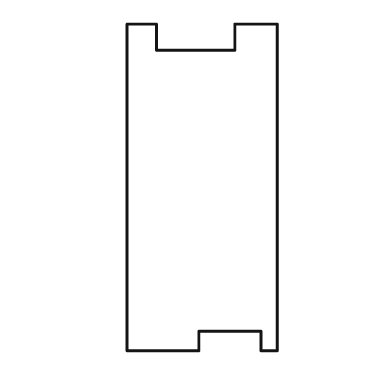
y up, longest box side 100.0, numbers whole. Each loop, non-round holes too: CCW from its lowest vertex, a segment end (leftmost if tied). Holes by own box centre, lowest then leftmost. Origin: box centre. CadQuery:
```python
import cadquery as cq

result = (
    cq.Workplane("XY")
    .moveTo(-23.0, -50.0)
    .lineTo(-1.0, -50.0)
    .lineTo(-1.0, -44.0)
    .lineTo(18.0, -44.0)
    .lineTo(18.0, -50.0)
    .lineTo(23.0, -50.0)
    .lineTo(23.0, 50.0)
    .lineTo(10.0, 50.0)
    .lineTo(10.0, 42.0)
    .lineTo(-14.0, 42.0)
    .lineTo(-14.0, 50.0)
    .lineTo(-23.0, 50.0)
    .close()
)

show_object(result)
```